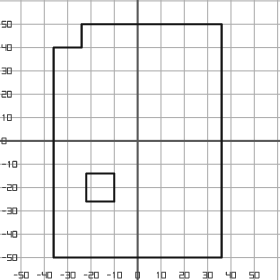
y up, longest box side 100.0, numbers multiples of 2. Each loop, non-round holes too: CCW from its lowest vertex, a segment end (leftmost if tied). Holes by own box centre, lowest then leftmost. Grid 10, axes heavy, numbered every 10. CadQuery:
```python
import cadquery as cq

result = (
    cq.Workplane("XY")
    .moveTo(-36.0, -50.0)
    .lineTo(36.0, -50.0)
    .lineTo(36.0, 50.0)
    .lineTo(-24.0, 50.0)
    .lineTo(-24.0, 40.0)
    .lineTo(-36.0, 40.0)
    .close()
    .moveTo(-22.0, -26.0)
    .lineTo(-10.0, -26.0)
    .lineTo(-10.0, -14.0)
    .lineTo(-22.0, -14.0)
    .close()
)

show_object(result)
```